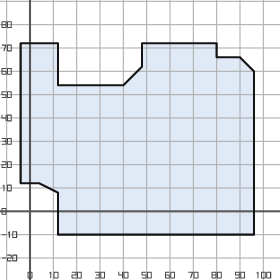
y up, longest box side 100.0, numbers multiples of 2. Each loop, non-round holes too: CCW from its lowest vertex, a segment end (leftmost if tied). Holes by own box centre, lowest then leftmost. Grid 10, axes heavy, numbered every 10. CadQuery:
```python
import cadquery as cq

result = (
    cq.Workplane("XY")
    .moveTo(12.0, -10.0)
    .lineTo(96.0, -10.0)
    .lineTo(96.0, 60.0)
    .lineTo(90.0, 66.0)
    .lineTo(80.0, 66.0)
    .lineTo(80.0, 72.0)
    .lineTo(48.0, 72.0)
    .lineTo(48.0, 62.0)
    .lineTo(40.0, 54.0)
    .lineTo(12.0, 54.0)
    .lineTo(12.0, 72.0)
    .lineTo(-4.0, 72.0)
    .lineTo(-4.0, 12.0)
    .lineTo(4.0, 12.0)
    .lineTo(12.0, 8.0)
    .close()
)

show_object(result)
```